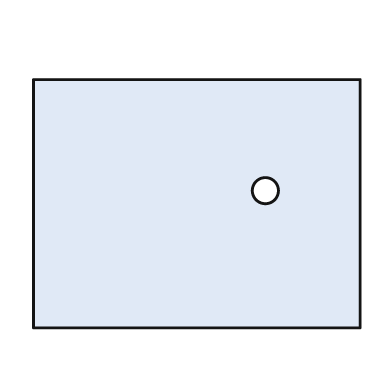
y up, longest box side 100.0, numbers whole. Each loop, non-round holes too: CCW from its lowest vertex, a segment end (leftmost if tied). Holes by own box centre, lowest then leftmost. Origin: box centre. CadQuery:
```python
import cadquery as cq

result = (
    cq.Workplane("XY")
    .moveTo(-50.0, -38.0)
    .lineTo(50.0, -38.0)
    .lineTo(50.0, 38.0)
    .lineTo(-50.0, 38.0)
    .close()
    .moveTo(21.0, 4.0)
    .circle(4.0)
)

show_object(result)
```